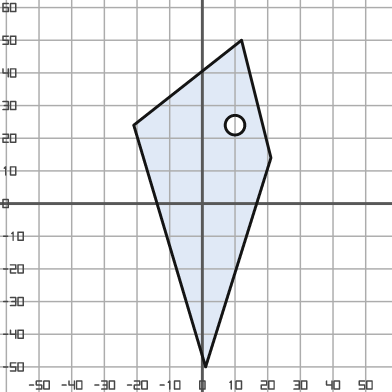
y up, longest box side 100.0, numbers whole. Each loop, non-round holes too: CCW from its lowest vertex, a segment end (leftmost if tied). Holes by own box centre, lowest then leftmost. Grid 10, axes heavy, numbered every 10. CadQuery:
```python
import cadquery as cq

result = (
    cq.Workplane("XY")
    .moveTo(1.0, -50.0)
    .lineTo(21.0, 14.0)
    .lineTo(12.0, 50.0)
    .lineTo(-21.0, 24.0)
    .close()
    .moveTo(10.0, 24.0)
    .circle(3.0)
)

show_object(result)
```